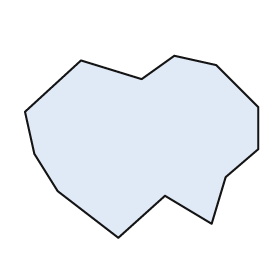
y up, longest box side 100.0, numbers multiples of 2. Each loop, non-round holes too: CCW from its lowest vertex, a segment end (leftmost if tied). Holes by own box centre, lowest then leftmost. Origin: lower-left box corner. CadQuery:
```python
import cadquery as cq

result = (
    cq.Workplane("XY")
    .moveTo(40.0, 0.0)
    .lineTo(60.0, 18.0)
    .lineTo(80.0, 6.0)
    .lineTo(86.0, 26.0)
    .lineTo(100.0, 38.0)
    .lineTo(100.0, 56.0)
    .lineTo(82.0, 74.0)
    .lineTo(64.0, 78.0)
    .lineTo(50.0, 68.0)
    .lineTo(24.0, 76.0)
    .lineTo(0.0, 54.0)
    .lineTo(4.0, 36.0)
    .lineTo(14.0, 20.0)
    .close()
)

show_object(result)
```